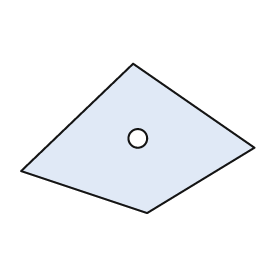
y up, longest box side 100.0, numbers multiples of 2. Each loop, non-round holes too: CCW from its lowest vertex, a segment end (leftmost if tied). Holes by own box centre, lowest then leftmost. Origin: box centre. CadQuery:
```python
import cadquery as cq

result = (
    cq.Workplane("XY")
    .moveTo(4.0, -32.0)
    .lineTo(50.0, -4.0)
    .lineTo(-2.0, 32.0)
    .lineTo(-50.0, -14.0)
    .close()
    .moveTo(0.0, 0.0)
    .circle(4.0)
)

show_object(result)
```